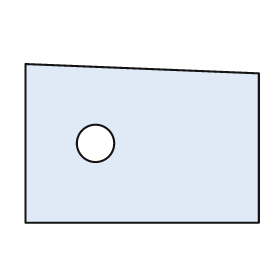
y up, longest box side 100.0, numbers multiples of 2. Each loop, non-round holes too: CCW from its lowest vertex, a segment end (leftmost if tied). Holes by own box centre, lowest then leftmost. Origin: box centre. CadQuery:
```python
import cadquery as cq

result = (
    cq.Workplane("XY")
    .moveTo(-50.0, -34.0)
    .lineTo(50.0, -34.0)
    .lineTo(50.0, 30.0)
    .lineTo(-50.0, 34.0)
    .close()
    .moveTo(-20.0, 0.0)
    .circle(8.0)
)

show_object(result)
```